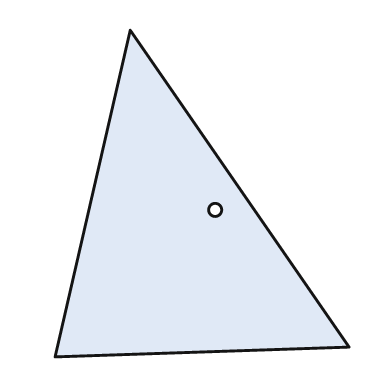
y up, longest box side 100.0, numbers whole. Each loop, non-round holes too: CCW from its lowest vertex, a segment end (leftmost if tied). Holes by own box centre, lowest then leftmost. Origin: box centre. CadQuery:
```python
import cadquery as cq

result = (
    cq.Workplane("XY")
    .moveTo(-45.0, -50.0)
    .lineTo(45.0, -47.0)
    .lineTo(-22.0, 50.0)
    .close()
    .moveTo(4.0, -5.0)
    .circle(2.0)
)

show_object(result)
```